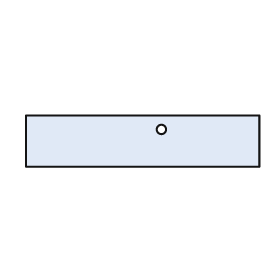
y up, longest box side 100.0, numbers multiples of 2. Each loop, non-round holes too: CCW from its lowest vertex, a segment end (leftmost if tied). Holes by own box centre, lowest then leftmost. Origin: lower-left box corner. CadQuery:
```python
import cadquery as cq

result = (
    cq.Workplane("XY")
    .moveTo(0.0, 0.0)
    .lineTo(100.0, 0.0)
    .lineTo(100.0, 22.0)
    .lineTo(0.0, 22.0)
    .close()
    .moveTo(58.0, 16.0)
    .circle(2.0)
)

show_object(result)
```